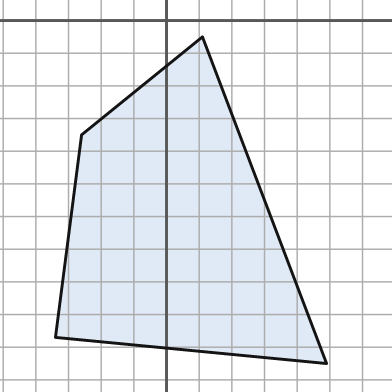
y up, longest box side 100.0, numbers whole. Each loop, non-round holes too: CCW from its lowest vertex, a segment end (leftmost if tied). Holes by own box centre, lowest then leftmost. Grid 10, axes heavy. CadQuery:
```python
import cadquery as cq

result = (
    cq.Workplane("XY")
    .moveTo(49.0, -105.0)
    .lineTo(11.0, -5.0)
    .lineTo(-26.0, -35.0)
    .lineTo(-34.0, -97.0)
    .close()
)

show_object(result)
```